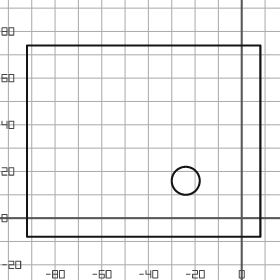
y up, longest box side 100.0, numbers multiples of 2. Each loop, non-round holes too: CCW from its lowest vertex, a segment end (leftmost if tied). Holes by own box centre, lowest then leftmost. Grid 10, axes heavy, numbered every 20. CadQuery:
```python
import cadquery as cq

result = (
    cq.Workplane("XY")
    .moveTo(-92.0, -8.0)
    .lineTo(8.0, -8.0)
    .lineTo(8.0, 74.0)
    .lineTo(-92.0, 74.0)
    .close()
    .moveTo(-24.0, 16.0)
    .circle(6.0)
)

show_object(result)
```